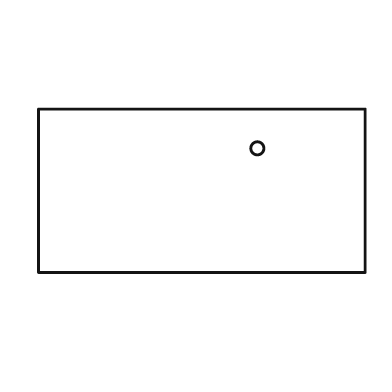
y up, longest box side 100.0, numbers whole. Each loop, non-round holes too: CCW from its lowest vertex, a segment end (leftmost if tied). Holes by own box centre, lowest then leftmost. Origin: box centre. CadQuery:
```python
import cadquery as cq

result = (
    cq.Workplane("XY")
    .moveTo(-50.0, -25.0)
    .lineTo(50.0, -25.0)
    .lineTo(50.0, 25.0)
    .lineTo(-50.0, 25.0)
    .close()
    .moveTo(17.0, 13.0)
    .circle(2.0)
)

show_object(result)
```